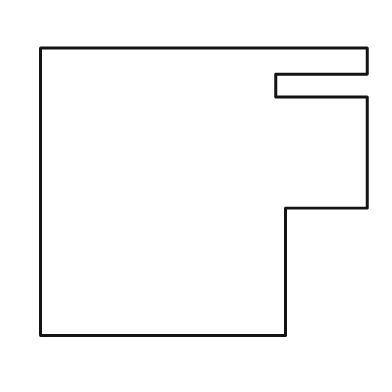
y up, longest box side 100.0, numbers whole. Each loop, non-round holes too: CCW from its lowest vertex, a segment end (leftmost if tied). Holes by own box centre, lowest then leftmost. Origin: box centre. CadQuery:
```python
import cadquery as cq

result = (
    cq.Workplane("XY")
    .moveTo(-50.0, -44.0)
    .lineTo(25.0, -44.0)
    .lineTo(25.0, -5.0)
    .lineTo(50.0, -5.0)
    .lineTo(50.0, 29.0)
    .lineTo(22.0, 29.0)
    .lineTo(22.0, 36.0)
    .lineTo(50.0, 36.0)
    .lineTo(50.0, 44.0)
    .lineTo(-50.0, 44.0)
    .close()
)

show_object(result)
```